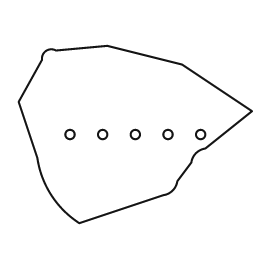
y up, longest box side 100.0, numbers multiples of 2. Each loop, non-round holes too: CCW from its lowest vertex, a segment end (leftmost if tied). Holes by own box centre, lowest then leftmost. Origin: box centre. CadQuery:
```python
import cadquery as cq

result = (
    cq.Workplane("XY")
    .moveTo(-24.0, -38.0)
    .lineTo(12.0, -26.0)
    .threePointArc((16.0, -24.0), (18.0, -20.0))
    .lineTo(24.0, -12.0)
    .threePointArc((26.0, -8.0), (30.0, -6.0))
    .lineTo(50.0, 10.0)
    .lineTo(20.0, 30.0)
    .lineTo(-12.0, 38.0)
    .lineTo(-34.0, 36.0)
    .threePointArc((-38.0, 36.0), (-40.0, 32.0))
    .lineTo(-50.0, 14.0)
    .lineTo(-42.0, -10.0)
    .threePointArc((-36.0, -26.0), (-24.0, -38.0))
    .close()
    .moveTo(-28.0, 0.0)
    .circle(2.0)
    .moveTo(-14.0, 0.0)
    .circle(2.0)
    .moveTo(0.0, 0.0)
    .circle(2.0)
    .moveTo(14.0, 0.0)
    .circle(2.0)
    .moveTo(28.0, 0.0)
    .circle(2.0)
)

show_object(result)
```